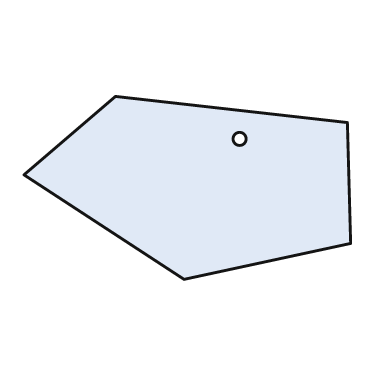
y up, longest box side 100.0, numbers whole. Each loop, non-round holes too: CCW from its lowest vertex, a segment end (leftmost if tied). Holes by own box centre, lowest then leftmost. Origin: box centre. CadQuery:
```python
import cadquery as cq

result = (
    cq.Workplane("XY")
    .moveTo(-1.0, -28.0)
    .lineTo(50.0, -17.0)
    .lineTo(49.0, 20.0)
    .lineTo(-22.0, 28.0)
    .lineTo(-50.0, 4.0)
    .close()
    .moveTo(16.0, 15.0)
    .circle(2.0)
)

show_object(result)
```